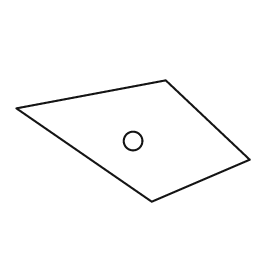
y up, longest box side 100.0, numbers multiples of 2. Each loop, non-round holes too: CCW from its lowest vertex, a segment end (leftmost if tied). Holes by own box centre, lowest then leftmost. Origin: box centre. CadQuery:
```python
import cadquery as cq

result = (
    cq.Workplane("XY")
    .moveTo(8.0, -26.0)
    .lineTo(50.0, -8.0)
    .lineTo(14.0, 26.0)
    .lineTo(-50.0, 14.0)
    .close()
    .moveTo(0.0, 0.0)
    .circle(4.0)
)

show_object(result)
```